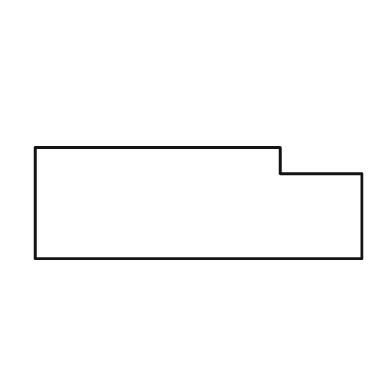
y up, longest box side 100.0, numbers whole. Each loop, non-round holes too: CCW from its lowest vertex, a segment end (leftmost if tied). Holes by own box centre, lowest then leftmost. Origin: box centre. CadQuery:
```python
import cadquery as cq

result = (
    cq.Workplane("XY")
    .moveTo(-50.0, -17.0)
    .lineTo(50.0, -17.0)
    .lineTo(50.0, 9.0)
    .lineTo(25.0, 9.0)
    .lineTo(25.0, 17.0)
    .lineTo(-50.0, 17.0)
    .close()
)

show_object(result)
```